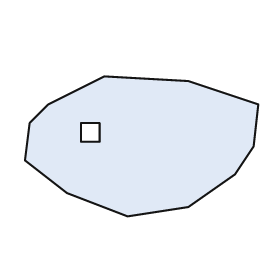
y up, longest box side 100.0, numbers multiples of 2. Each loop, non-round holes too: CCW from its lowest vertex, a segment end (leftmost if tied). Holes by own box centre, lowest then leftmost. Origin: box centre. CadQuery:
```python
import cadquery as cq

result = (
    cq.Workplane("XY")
    .moveTo(-6.0, -30.0)
    .lineTo(20.0, -26.0)
    .lineTo(40.0, -12.0)
    .lineTo(48.0, 0.0)
    .lineTo(50.0, 18.0)
    .lineTo(20.0, 28.0)
    .lineTo(-16.0, 30.0)
    .lineTo(-40.0, 18.0)
    .lineTo(-48.0, 10.0)
    .lineTo(-50.0, -6.0)
    .lineTo(-32.0, -20.0)
    .close()
    .moveTo(-26.0, 2.0)
    .lineTo(-18.0, 2.0)
    .lineTo(-18.0, 10.0)
    .lineTo(-26.0, 10.0)
    .close()
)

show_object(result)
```